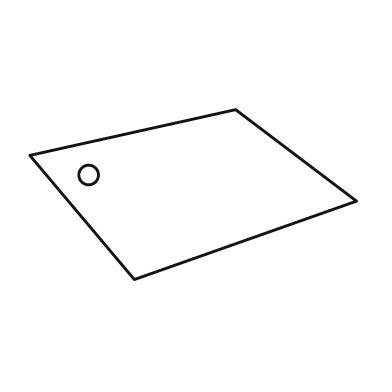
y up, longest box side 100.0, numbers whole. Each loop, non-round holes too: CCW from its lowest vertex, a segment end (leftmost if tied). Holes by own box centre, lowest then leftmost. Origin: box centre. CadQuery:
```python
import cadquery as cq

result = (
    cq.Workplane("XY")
    .moveTo(-18.0, -26.0)
    .lineTo(50.0, -2.0)
    .lineTo(13.0, 26.0)
    .lineTo(-50.0, 12.0)
    .close()
    .moveTo(-32.0, 6.0)
    .circle(3.0)
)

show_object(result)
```